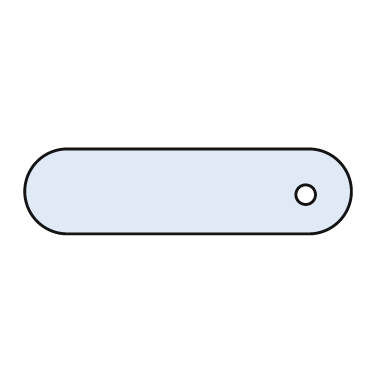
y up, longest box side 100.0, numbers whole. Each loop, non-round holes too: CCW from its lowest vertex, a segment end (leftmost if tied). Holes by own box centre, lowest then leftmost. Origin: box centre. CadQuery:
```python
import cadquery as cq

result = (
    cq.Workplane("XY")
    .moveTo(-37.0, -13.0)
    .lineTo(37.0, -13.0)
    .threePointArc((50.0, 0.0), (37.0, 13.0))
    .lineTo(-37.0, 13.0)
    .threePointArc((-50.0, 0.0), (-37.0, -13.0))
    .close()
    .moveTo(36.0, -1.0)
    .circle(3.0)
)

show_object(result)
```